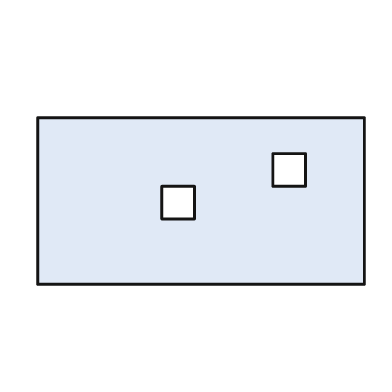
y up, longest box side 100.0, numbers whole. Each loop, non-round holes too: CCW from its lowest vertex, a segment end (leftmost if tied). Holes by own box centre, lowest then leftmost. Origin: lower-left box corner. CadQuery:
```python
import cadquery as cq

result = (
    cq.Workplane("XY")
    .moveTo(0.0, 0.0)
    .lineTo(100.0, 0.0)
    .lineTo(100.0, 51.0)
    .lineTo(0.0, 51.0)
    .close()
    .moveTo(38.0, 20.0)
    .lineTo(48.0, 20.0)
    .lineTo(48.0, 30.0)
    .lineTo(38.0, 30.0)
    .close()
    .moveTo(72.0, 30.0)
    .lineTo(82.0, 30.0)
    .lineTo(82.0, 40.0)
    .lineTo(72.0, 40.0)
    .close()
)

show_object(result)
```